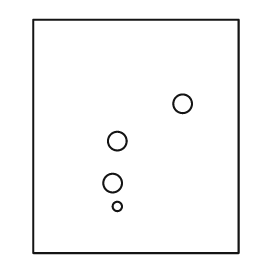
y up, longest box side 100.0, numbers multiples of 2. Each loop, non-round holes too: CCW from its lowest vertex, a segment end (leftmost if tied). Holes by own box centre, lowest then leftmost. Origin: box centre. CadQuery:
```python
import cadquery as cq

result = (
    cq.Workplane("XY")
    .moveTo(-44.0, -50.0)
    .lineTo(44.0, -50.0)
    .lineTo(44.0, 50.0)
    .lineTo(-44.0, 50.0)
    .close()
    .moveTo(-8.0, -30.0)
    .circle(2.0)
    .moveTo(-10.0, -20.0)
    .circle(4.0)
    .moveTo(-8.0, -2.0)
    .circle(4.0)
    .moveTo(20.0, 14.0)
    .circle(4.0)
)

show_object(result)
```